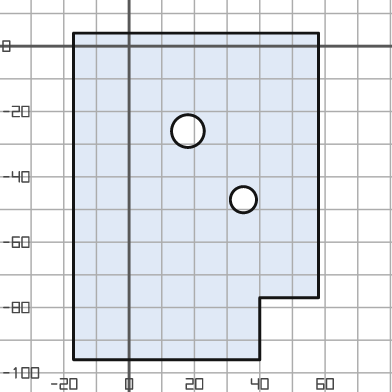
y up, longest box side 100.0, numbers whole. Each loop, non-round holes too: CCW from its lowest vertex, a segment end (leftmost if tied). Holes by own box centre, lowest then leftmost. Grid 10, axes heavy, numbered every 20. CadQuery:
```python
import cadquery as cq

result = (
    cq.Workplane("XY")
    .moveTo(-17.0, -96.0)
    .lineTo(40.0, -96.0)
    .lineTo(40.0, -77.0)
    .lineTo(58.0, -77.0)
    .lineTo(58.0, 4.0)
    .lineTo(-17.0, 4.0)
    .close()
    .moveTo(35.0, -47.0)
    .circle(4.0)
    .moveTo(18.0, -26.0)
    .circle(5.0)
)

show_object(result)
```